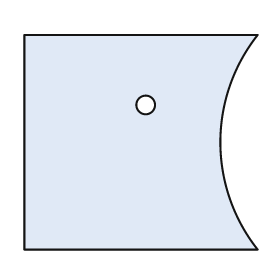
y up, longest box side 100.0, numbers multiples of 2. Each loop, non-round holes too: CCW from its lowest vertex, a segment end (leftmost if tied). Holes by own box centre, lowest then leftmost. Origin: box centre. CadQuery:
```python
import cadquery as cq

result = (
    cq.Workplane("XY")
    .moveTo(-50.0, -46.0)
    .lineTo(50.0, -46.0)
    .threePointArc((34.0, 0.0), (50.0, 46.0))
    .lineTo(-50.0, 46.0)
    .close()
    .moveTo(2.0, 16.0)
    .circle(4.0)
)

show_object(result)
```